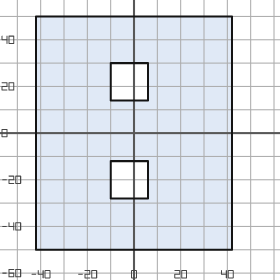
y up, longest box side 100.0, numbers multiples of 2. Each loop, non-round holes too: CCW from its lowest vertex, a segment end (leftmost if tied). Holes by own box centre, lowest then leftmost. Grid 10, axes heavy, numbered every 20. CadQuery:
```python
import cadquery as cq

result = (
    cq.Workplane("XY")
    .moveTo(-42.0, -50.0)
    .lineTo(42.0, -50.0)
    .lineTo(42.0, 50.0)
    .lineTo(-42.0, 50.0)
    .close()
    .moveTo(-10.0, -28.0)
    .lineTo(6.0, -28.0)
    .lineTo(6.0, -12.0)
    .lineTo(-10.0, -12.0)
    .close()
    .moveTo(-10.0, 14.0)
    .lineTo(6.0, 14.0)
    .lineTo(6.0, 30.0)
    .lineTo(-10.0, 30.0)
    .close()
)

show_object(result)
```